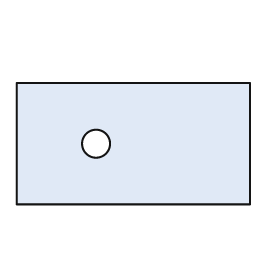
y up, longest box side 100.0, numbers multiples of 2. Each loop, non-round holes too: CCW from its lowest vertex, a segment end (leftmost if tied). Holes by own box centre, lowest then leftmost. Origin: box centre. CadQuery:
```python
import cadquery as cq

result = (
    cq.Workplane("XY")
    .moveTo(-50.0, -26.0)
    .lineTo(50.0, -26.0)
    .lineTo(50.0, 26.0)
    .lineTo(-50.0, 26.0)
    .close()
    .moveTo(-16.0, 0.0)
    .circle(6.0)
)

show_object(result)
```